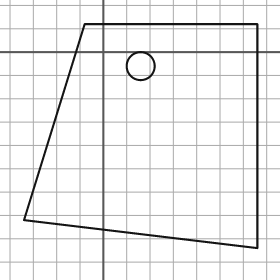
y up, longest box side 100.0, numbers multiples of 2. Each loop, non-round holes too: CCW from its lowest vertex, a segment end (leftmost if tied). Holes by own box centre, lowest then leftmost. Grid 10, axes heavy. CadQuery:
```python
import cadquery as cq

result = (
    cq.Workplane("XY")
    .moveTo(66.0, -84.0)
    .lineTo(66.0, 12.0)
    .lineTo(-8.0, 12.0)
    .lineTo(-34.0, -72.0)
    .close()
    .moveTo(16.0, -6.0)
    .circle(6.0)
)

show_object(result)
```